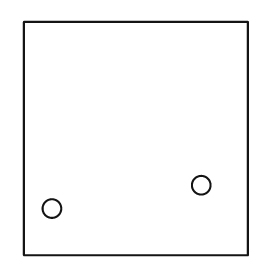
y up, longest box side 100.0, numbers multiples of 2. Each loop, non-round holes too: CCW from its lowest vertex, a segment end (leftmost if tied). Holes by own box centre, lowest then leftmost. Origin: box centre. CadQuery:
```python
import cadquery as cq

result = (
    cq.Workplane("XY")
    .moveTo(-48.0, -50.0)
    .lineTo(48.0, -50.0)
    .lineTo(48.0, 50.0)
    .lineTo(-48.0, 50.0)
    .close()
    .moveTo(-36.0, -30.0)
    .circle(4.0)
    .moveTo(28.0, -20.0)
    .circle(4.0)
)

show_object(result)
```